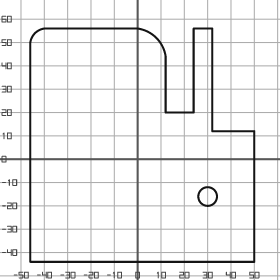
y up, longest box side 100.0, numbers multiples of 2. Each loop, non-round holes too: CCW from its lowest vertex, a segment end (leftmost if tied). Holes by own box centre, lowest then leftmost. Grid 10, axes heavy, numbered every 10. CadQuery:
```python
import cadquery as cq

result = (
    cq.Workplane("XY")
    .moveTo(-46.0, -44.0)
    .lineTo(50.0, -44.0)
    .lineTo(50.0, 12.0)
    .lineTo(32.0, 12.0)
    .lineTo(32.0, 56.0)
    .lineTo(24.0, 56.0)
    .lineTo(24.0, 20.0)
    .lineTo(12.0, 20.0)
    .lineTo(12.0, 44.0)
    .threePointArc((8.0, 52.0), (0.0, 56.0))
    .lineTo(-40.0, 56.0)
    .threePointArc((-44.0, 54.0), (-46.0, 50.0))
    .close()
    .moveTo(30.0, -16.0)
    .circle(4.0)
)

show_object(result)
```